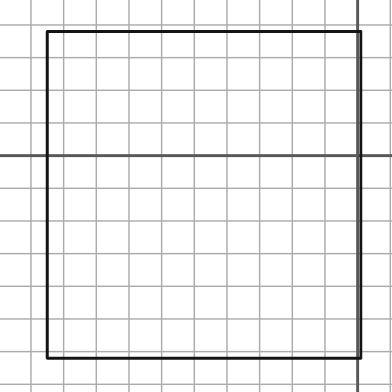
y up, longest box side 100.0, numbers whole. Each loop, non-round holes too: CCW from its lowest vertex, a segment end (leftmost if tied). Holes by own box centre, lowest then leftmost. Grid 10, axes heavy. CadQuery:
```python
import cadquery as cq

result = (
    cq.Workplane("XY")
    .moveTo(-95.0, -62.0)
    .lineTo(1.0, -62.0)
    .lineTo(1.0, 38.0)
    .lineTo(-95.0, 38.0)
    .close()
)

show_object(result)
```